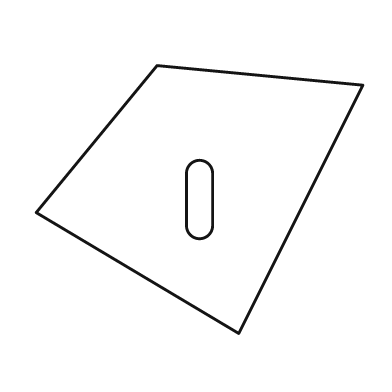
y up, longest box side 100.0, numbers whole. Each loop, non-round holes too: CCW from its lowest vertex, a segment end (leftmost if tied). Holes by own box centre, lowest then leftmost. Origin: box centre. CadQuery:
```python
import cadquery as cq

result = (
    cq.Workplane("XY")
    .moveTo(12.0, -41.0)
    .lineTo(50.0, 35.0)
    .lineTo(-13.0, 41.0)
    .lineTo(-50.0, -4.0)
    .close()
    .moveTo(-4.0, -8.0)
    .threePointArc((0.0, -12.0), (4.0, -8.0))
    .lineTo(4.0, 8.0)
    .threePointArc((0.0, 12.0), (-4.0, 8.0))
    .close()
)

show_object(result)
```